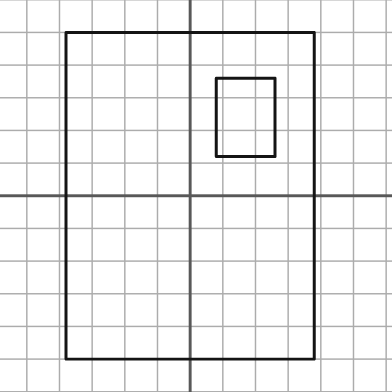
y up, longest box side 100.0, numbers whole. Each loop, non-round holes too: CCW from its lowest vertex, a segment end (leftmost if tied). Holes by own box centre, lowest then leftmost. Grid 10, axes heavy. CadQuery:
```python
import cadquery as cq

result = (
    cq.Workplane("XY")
    .moveTo(-38.0, -50.0)
    .lineTo(38.0, -50.0)
    .lineTo(38.0, 50.0)
    .lineTo(-38.0, 50.0)
    .close()
    .moveTo(8.0, 12.0)
    .lineTo(26.0, 12.0)
    .lineTo(26.0, 36.0)
    .lineTo(8.0, 36.0)
    .close()
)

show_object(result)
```